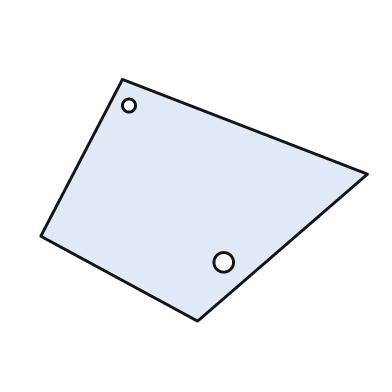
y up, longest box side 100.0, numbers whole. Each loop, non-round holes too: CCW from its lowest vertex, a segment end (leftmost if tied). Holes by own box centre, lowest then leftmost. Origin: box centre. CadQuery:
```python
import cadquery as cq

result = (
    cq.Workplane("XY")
    .moveTo(-2.0, -37.0)
    .lineTo(50.0, 8.0)
    .lineTo(-25.0, 37.0)
    .lineTo(-50.0, -11.0)
    .close()
    .moveTo(6.0, -19.0)
    .circle(3.0)
    .moveTo(-23.0, 29.0)
    .circle(2.0)
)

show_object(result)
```